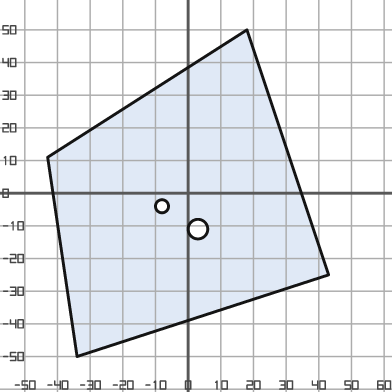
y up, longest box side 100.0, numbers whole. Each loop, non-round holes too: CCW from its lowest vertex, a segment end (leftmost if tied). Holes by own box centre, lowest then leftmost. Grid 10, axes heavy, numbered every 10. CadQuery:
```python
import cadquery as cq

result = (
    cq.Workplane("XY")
    .moveTo(-34.0, -50.0)
    .lineTo(43.0, -25.0)
    .lineTo(18.0, 50.0)
    .lineTo(-43.0, 11.0)
    .close()
    .moveTo(3.0, -11.0)
    .circle(3.0)
    .moveTo(-8.0, -4.0)
    .circle(2.0)
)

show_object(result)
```